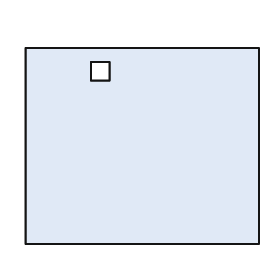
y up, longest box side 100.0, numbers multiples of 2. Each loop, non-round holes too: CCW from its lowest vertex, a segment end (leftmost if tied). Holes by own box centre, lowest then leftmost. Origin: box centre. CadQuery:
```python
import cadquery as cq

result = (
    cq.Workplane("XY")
    .moveTo(-50.0, -42.0)
    .lineTo(50.0, -42.0)
    .lineTo(50.0, 42.0)
    .lineTo(-50.0, 42.0)
    .close()
    .moveTo(-22.0, 28.0)
    .lineTo(-14.0, 28.0)
    .lineTo(-14.0, 36.0)
    .lineTo(-22.0, 36.0)
    .close()
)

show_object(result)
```